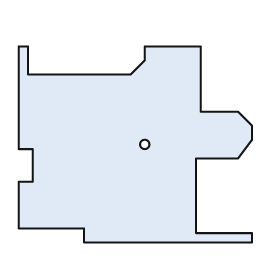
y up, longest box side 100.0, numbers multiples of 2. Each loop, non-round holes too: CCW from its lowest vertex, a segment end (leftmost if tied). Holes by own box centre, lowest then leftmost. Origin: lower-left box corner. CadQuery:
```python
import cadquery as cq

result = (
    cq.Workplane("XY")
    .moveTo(28.0, 0.0)
    .lineTo(100.0, 0.0)
    .lineTo(100.0, 4.0)
    .lineTo(76.0, 4.0)
    .lineTo(76.0, 36.0)
    .lineTo(94.0, 36.0)
    .lineTo(100.0, 44.0)
    .lineTo(100.0, 50.0)
    .lineTo(94.0, 56.0)
    .lineTo(78.0, 56.0)
    .lineTo(78.0, 84.0)
    .lineTo(54.0, 84.0)
    .lineTo(54.0, 78.0)
    .lineTo(48.0, 72.0)
    .lineTo(4.0, 72.0)
    .lineTo(4.0, 84.0)
    .lineTo(0.0, 84.0)
    .lineTo(0.0, 40.0)
    .lineTo(6.0, 40.0)
    .lineTo(6.0, 26.0)
    .lineTo(0.0, 26.0)
    .lineTo(0.0, 6.0)
    .lineTo(28.0, 6.0)
    .close()
    .moveTo(54.0, 42.0)
    .circle(2.0)
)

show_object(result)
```